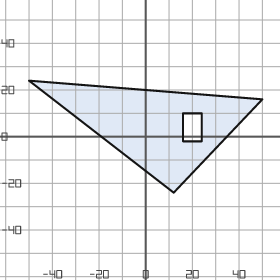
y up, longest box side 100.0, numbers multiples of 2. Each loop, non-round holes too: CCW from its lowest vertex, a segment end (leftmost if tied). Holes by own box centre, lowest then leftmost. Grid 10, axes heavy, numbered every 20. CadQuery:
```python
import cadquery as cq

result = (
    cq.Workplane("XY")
    .moveTo(12.0, -24.0)
    .lineTo(50.0, 16.0)
    .lineTo(-50.0, 24.0)
    .close()
    .moveTo(16.0, -2.0)
    .lineTo(24.0, -2.0)
    .lineTo(24.0, 10.0)
    .lineTo(16.0, 10.0)
    .close()
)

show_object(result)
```